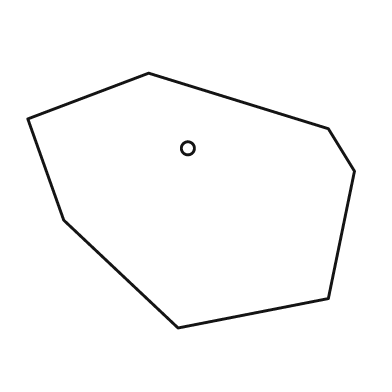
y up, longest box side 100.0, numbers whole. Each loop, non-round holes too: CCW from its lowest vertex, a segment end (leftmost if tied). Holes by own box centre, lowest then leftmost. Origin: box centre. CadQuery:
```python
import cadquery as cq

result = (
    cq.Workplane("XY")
    .moveTo(-4.0, -39.0)
    .lineTo(42.0, -30.0)
    .lineTo(50.0, 9.0)
    .lineTo(42.0, 22.0)
    .lineTo(-13.0, 39.0)
    .lineTo(-50.0, 25.0)
    .lineTo(-39.0, -6.0)
    .close()
    .moveTo(-1.0, 16.0)
    .circle(2.0)
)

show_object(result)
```